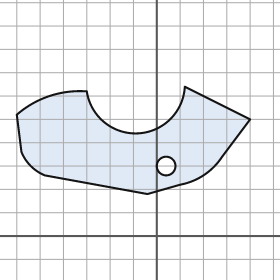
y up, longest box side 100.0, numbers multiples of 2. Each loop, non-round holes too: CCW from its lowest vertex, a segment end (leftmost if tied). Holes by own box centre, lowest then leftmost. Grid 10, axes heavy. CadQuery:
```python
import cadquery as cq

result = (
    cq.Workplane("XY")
    .moveTo(-4.0, 18.0)
    .lineTo(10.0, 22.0)
    .threePointArc((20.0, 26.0), (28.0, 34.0))
    .lineTo(40.0, 50.0)
    .lineTo(12.0, 64.0)
    .threePointArc((-8.0, 44.0), (-30.0, 62.0))
    .threePointArc((-46.0, 60.0), (-60.0, 52.0))
    .lineTo(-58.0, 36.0)
    .threePointArc((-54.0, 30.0), (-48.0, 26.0))
    .close()
    .moveTo(4.0, 30.0)
    .circle(4.0)
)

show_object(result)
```